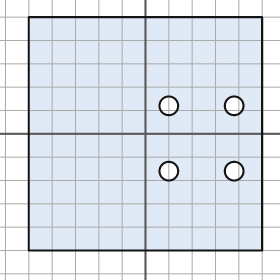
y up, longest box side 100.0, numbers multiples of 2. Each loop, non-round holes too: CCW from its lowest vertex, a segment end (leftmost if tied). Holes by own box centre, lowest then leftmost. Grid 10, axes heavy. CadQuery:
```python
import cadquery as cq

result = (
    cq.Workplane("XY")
    .moveTo(-50.0, -50.0)
    .lineTo(50.0, -50.0)
    .lineTo(50.0, 50.0)
    .lineTo(-50.0, 50.0)
    .close()
    .moveTo(10.0, -16.0)
    .circle(4.0)
    .moveTo(38.0, -16.0)
    .circle(4.0)
    .moveTo(10.0, 12.0)
    .circle(4.0)
    .moveTo(38.0, 12.0)
    .circle(4.0)
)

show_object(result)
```